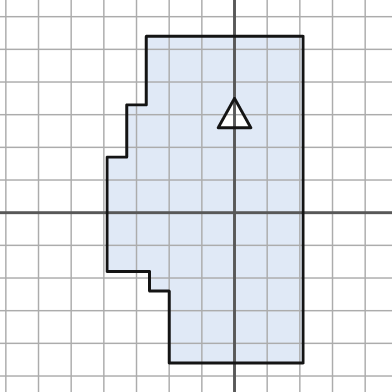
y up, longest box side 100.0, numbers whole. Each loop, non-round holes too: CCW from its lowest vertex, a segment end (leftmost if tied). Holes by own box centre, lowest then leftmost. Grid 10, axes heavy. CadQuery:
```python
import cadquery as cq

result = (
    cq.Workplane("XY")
    .moveTo(-20.0, -46.0)
    .lineTo(21.0, -46.0)
    .lineTo(21.0, 54.0)
    .lineTo(-27.0, 54.0)
    .lineTo(-27.0, 33.0)
    .lineTo(-33.0, 33.0)
    .lineTo(-33.0, 17.0)
    .lineTo(-39.0, 17.0)
    .lineTo(-39.0, -18.0)
    .lineTo(-26.0, -18.0)
    .lineTo(-26.0, -24.0)
    .lineTo(-20.0, -24.0)
    .close()
    .moveTo(-5.0, 26.0)
    .lineTo(5.0, 26.0)
    .lineTo(0.0, 35.0)
    .close()
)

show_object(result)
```